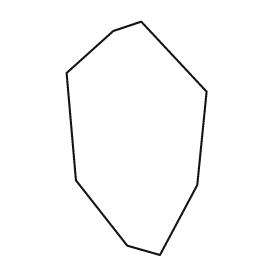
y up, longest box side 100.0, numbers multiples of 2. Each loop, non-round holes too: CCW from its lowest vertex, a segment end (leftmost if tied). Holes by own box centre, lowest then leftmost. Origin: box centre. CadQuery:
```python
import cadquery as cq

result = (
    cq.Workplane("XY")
    .moveTo(10.0, -50.0)
    .lineTo(26.0, -20.0)
    .lineTo(30.0, 20.0)
    .lineTo(2.0, 50.0)
    .lineTo(-10.0, 46.0)
    .lineTo(-30.0, 28.0)
    .lineTo(-26.0, -18.0)
    .lineTo(-4.0, -46.0)
    .close()
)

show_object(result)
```